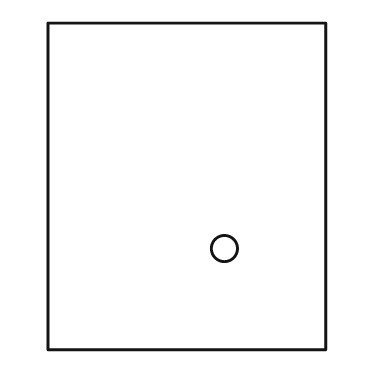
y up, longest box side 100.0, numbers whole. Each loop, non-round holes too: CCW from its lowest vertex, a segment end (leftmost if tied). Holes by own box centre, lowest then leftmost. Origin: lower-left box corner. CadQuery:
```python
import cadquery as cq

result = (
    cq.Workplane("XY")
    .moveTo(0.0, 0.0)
    .lineTo(85.0, 0.0)
    .lineTo(85.0, 100.0)
    .lineTo(0.0, 100.0)
    .close()
    .moveTo(54.0, 31.0)
    .circle(4.0)
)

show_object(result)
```